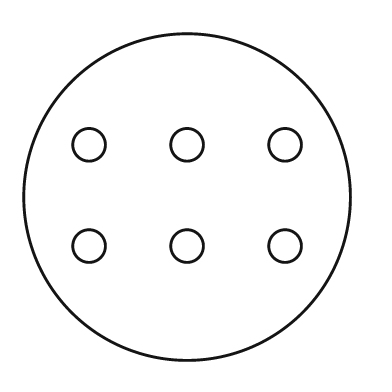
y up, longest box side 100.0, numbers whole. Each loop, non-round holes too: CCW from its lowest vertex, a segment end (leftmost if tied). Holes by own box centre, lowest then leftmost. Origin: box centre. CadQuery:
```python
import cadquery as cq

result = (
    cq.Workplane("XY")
    .moveTo(0.0, 0.0)
    .circle(50.0)
    .moveTo(-30.0, -15.0)
    .circle(5.0)
    .moveTo(0.0, -15.0)
    .circle(5.0)
    .moveTo(30.0, -15.0)
    .circle(5.0)
    .moveTo(-30.0, 16.0)
    .circle(5.0)
    .moveTo(0.0, 16.0)
    .circle(5.0)
    .moveTo(30.0, 16.0)
    .circle(5.0)
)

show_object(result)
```